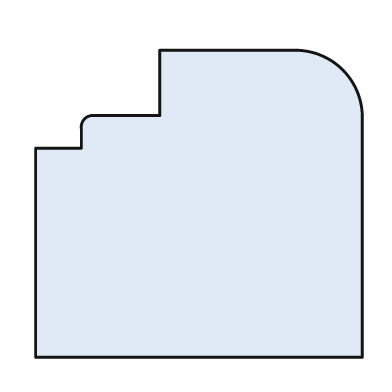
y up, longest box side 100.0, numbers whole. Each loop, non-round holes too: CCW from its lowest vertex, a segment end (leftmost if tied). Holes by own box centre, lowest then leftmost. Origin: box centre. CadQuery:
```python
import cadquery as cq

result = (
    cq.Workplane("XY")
    .moveTo(-50.0, -47.0)
    .lineTo(50.0, -47.0)
    .lineTo(50.0, 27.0)
    .threePointArc((44.0, 41.0), (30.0, 47.0))
    .lineTo(-12.0, 47.0)
    .lineTo(-12.0, 27.0)
    .lineTo(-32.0, 27.0)
    .threePointArc((-35.0, 26.0), (-36.0, 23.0))
    .lineTo(-36.0, 17.0)
    .lineTo(-50.0, 17.0)
    .close()
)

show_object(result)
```